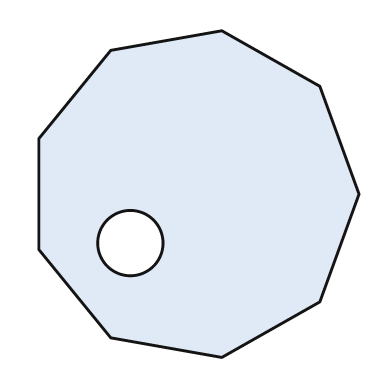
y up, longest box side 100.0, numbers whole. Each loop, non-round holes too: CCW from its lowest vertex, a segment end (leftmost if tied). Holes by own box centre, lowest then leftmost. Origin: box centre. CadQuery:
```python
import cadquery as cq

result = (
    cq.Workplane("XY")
    .moveTo(7.0, -50.0)
    .lineTo(37.0, -33.0)
    .lineTo(49.0, 0.0)
    .lineTo(37.0, 33.0)
    .lineTo(7.0, 50.0)
    .lineTo(-27.0, 44.0)
    .lineTo(-49.0, 17.0)
    .lineTo(-49.0, -17.0)
    .lineTo(-27.0, -44.0)
    .close()
    .moveTo(-21.0, -15.0)
    .circle(10.0)
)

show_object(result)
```